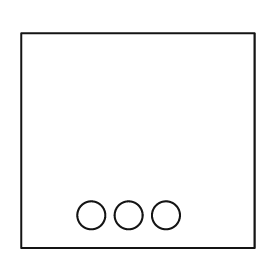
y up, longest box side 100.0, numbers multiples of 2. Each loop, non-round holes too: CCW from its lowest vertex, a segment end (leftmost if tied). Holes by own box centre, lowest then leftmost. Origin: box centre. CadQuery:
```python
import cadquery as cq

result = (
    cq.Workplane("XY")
    .moveTo(-50.0, -46.0)
    .lineTo(50.0, -46.0)
    .lineTo(50.0, 46.0)
    .lineTo(-50.0, 46.0)
    .close()
    .moveTo(-20.0, -32.0)
    .circle(6.0)
    .moveTo(-4.0, -32.0)
    .circle(6.0)
    .moveTo(12.0, -32.0)
    .circle(6.0)
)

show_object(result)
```